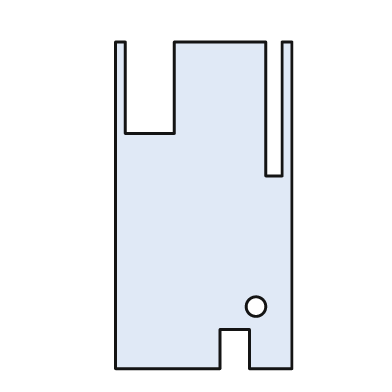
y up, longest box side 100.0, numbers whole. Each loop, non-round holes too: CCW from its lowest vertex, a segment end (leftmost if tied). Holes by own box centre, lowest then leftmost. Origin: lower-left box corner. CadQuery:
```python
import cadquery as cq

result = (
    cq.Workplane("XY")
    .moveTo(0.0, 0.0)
    .lineTo(32.0, 0.0)
    .lineTo(32.0, 12.0)
    .lineTo(41.0, 12.0)
    .lineTo(41.0, 0.0)
    .lineTo(54.0, 0.0)
    .lineTo(54.0, 100.0)
    .lineTo(51.0, 100.0)
    .lineTo(51.0, 59.0)
    .lineTo(46.0, 59.0)
    .lineTo(46.0, 100.0)
    .lineTo(18.0, 100.0)
    .lineTo(18.0, 72.0)
    .lineTo(3.0, 72.0)
    .lineTo(3.0, 100.0)
    .lineTo(0.0, 100.0)
    .close()
    .moveTo(43.0, 19.0)
    .circle(3.0)
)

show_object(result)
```